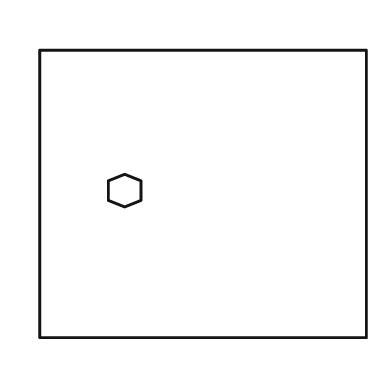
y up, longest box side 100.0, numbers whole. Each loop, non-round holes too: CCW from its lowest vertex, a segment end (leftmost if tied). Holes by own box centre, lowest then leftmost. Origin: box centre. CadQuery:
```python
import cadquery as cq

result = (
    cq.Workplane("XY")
    .moveTo(-50.0, -44.0)
    .lineTo(50.0, -44.0)
    .lineTo(50.0, 44.0)
    .lineTo(-50.0, 44.0)
    .close()
    .moveTo(-24.0, -4.0)
    .lineTo(-19.0, -2.0)
    .lineTo(-19.0, 4.0)
    .lineTo(-24.0, 6.0)
    .lineTo(-29.0, 4.0)
    .lineTo(-29.0, -2.0)
    .close()
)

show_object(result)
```